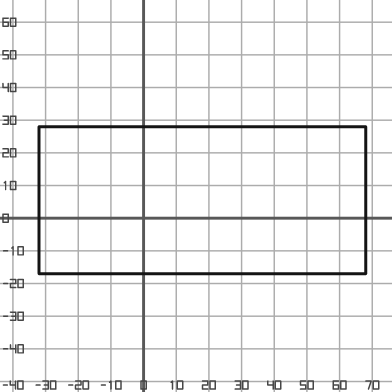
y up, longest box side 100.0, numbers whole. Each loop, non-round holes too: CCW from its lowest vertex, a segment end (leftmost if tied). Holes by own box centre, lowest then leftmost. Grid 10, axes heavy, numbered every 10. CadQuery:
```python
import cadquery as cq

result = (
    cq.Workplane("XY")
    .moveTo(-32.0, -17.0)
    .lineTo(68.0, -17.0)
    .lineTo(68.0, 28.0)
    .lineTo(-32.0, 28.0)
    .close()
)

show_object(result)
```